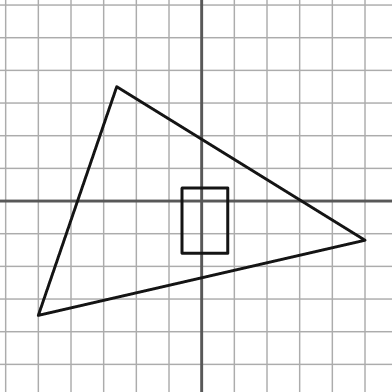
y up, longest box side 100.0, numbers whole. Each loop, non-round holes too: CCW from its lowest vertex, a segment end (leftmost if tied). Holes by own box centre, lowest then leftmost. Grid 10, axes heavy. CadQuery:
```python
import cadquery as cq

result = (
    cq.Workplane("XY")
    .moveTo(-50.0, -35.0)
    .lineTo(50.0, -12.0)
    .lineTo(-26.0, 35.0)
    .close()
    .moveTo(-6.0, -16.0)
    .lineTo(8.0, -16.0)
    .lineTo(8.0, 4.0)
    .lineTo(-6.0, 4.0)
    .close()
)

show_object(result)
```